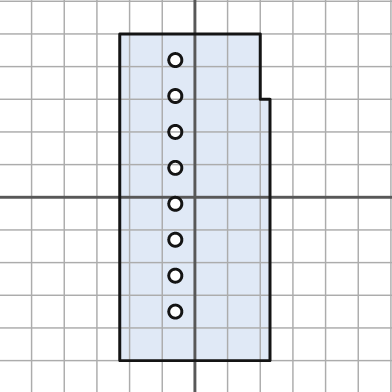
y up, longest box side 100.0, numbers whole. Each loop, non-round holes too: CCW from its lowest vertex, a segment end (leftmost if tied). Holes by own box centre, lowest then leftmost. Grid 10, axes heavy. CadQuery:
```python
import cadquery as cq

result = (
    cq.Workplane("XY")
    .moveTo(-23.0, -50.0)
    .lineTo(23.0, -50.0)
    .lineTo(23.0, 30.0)
    .lineTo(20.0, 30.0)
    .lineTo(20.0, 50.0)
    .lineTo(-23.0, 50.0)
    .close()
    .moveTo(-6.0, -35.0)
    .circle(2.0)
    .moveTo(-6.0, -24.0)
    .circle(2.0)
    .moveTo(-6.0, -13.0)
    .circle(2.0)
    .moveTo(-6.0, -2.0)
    .circle(2.0)
    .moveTo(-6.0, 9.0)
    .circle(2.0)
    .moveTo(-6.0, 20.0)
    .circle(2.0)
    .moveTo(-6.0, 31.0)
    .circle(2.0)
    .moveTo(-6.0, 42.0)
    .circle(2.0)
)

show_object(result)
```